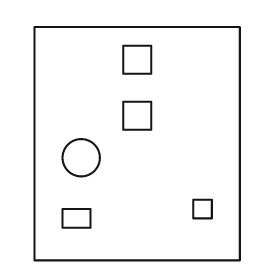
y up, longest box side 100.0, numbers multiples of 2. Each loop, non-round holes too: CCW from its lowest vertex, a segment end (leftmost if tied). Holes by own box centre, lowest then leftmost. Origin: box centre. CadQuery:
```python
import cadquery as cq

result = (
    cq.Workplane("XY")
    .moveTo(-44.0, -50.0)
    .lineTo(44.0, -50.0)
    .lineTo(44.0, 50.0)
    .lineTo(-44.0, 50.0)
    .close()
    .moveTo(-32.0, -36.0)
    .lineTo(-20.0, -36.0)
    .lineTo(-20.0, -28.0)
    .lineTo(-32.0, -28.0)
    .close()
    .moveTo(24.0, -32.0)
    .lineTo(32.0, -32.0)
    .lineTo(32.0, -24.0)
    .lineTo(24.0, -24.0)
    .close()
    .moveTo(-24.0, -6.0)
    .circle(8.0)
    .moveTo(-6.0, 6.0)
    .lineTo(6.0, 6.0)
    .lineTo(6.0, 18.0)
    .lineTo(-6.0, 18.0)
    .close()
    .moveTo(-6.0, 30.0)
    .lineTo(6.0, 30.0)
    .lineTo(6.0, 42.0)
    .lineTo(-6.0, 42.0)
    .close()
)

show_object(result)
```